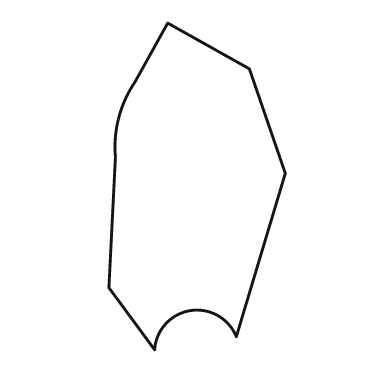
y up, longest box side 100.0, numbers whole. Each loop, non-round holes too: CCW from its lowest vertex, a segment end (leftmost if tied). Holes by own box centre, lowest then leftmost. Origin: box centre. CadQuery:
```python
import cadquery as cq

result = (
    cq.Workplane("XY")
    .moveTo(-13.0, -50.0)
    .threePointArc((-2.0, -38.0), (12.0, -46.0))
    .lineTo(27.0, 4.0)
    .lineTo(16.0, 36.0)
    .lineTo(-9.0, 50.0)
    .lineTo(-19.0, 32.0)
    .threePointArc((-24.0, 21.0), (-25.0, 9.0))
    .lineTo(-27.0, -31.0)
    .close()
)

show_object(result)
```